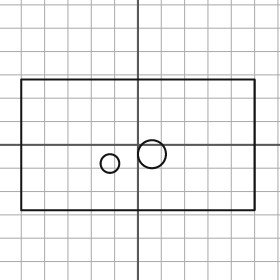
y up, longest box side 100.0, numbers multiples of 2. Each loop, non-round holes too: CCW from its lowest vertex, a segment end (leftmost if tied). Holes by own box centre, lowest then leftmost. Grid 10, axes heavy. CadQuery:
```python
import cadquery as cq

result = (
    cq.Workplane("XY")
    .moveTo(-50.0, -28.0)
    .lineTo(50.0, -28.0)
    .lineTo(50.0, 28.0)
    .lineTo(-50.0, 28.0)
    .close()
    .moveTo(-12.0, -8.0)
    .circle(4.0)
    .moveTo(6.0, -4.0)
    .circle(6.0)
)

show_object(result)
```